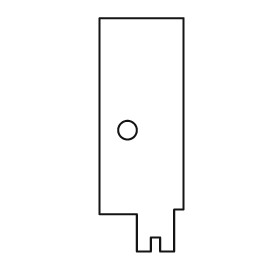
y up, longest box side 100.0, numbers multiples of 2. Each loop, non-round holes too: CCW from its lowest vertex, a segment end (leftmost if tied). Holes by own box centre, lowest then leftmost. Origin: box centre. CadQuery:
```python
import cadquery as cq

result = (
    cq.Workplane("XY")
    .moveTo(-2.0, -50.0)
    .lineTo(4.0, -50.0)
    .lineTo(4.0, -44.0)
    .lineTo(8.0, -44.0)
    .lineTo(8.0, -50.0)
    .lineTo(14.0, -50.0)
    .lineTo(14.0, -32.0)
    .lineTo(18.0, -32.0)
    .lineTo(18.0, 50.0)
    .lineTo(-18.0, 50.0)
    .lineTo(-18.0, -34.0)
    .lineTo(-2.0, -34.0)
    .close()
    .moveTo(-6.0, 2.0)
    .circle(4.0)
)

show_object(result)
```